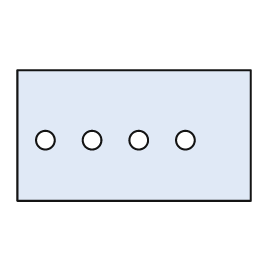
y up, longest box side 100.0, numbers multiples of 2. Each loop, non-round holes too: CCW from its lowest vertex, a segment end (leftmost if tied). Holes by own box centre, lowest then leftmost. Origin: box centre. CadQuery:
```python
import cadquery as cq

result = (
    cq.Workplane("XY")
    .moveTo(-50.0, -28.0)
    .lineTo(50.0, -28.0)
    .lineTo(50.0, 28.0)
    .lineTo(-50.0, 28.0)
    .close()
    .moveTo(-38.0, -2.0)
    .circle(4.0)
    .moveTo(-18.0, -2.0)
    .circle(4.0)
    .moveTo(2.0, -2.0)
    .circle(4.0)
    .moveTo(22.0, -2.0)
    .circle(4.0)
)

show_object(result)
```